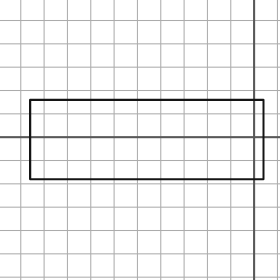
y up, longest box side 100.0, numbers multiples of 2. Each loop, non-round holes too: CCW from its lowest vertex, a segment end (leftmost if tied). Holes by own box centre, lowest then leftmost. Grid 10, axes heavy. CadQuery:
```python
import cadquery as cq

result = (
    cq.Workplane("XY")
    .moveTo(-96.0, -18.0)
    .lineTo(4.0, -18.0)
    .lineTo(4.0, 16.0)
    .lineTo(-96.0, 16.0)
    .close()
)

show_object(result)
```